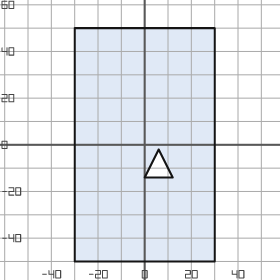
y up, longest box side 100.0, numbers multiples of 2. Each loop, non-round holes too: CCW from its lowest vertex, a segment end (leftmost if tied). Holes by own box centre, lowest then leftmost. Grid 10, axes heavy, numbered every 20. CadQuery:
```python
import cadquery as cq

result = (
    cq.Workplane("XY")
    .moveTo(-30.0, -50.0)
    .lineTo(30.0, -50.0)
    .lineTo(30.0, 50.0)
    .lineTo(-30.0, 50.0)
    .close()
    .moveTo(0.0, -14.0)
    .lineTo(12.0, -14.0)
    .lineTo(6.0, -2.0)
    .close()
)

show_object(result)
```